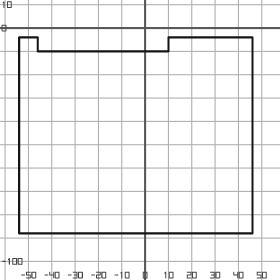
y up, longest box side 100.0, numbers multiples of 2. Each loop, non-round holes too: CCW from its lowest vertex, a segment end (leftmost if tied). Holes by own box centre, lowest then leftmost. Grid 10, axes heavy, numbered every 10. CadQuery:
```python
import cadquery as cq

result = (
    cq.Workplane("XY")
    .moveTo(-54.0, -88.0)
    .lineTo(46.0, -88.0)
    .lineTo(46.0, -4.0)
    .lineTo(10.0, -4.0)
    .lineTo(10.0, -10.0)
    .lineTo(-46.0, -10.0)
    .lineTo(-46.0, -4.0)
    .lineTo(-54.0, -4.0)
    .close()
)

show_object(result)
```